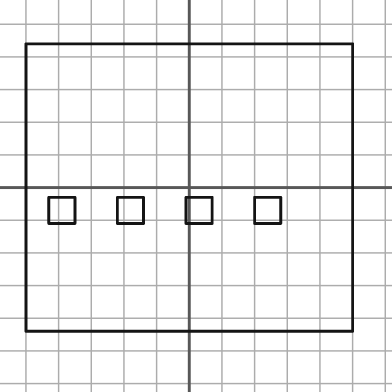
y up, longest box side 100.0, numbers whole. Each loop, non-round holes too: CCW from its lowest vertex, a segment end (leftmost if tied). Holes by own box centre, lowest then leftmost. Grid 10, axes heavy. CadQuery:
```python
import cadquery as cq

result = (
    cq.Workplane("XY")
    .moveTo(-50.0, -44.0)
    .lineTo(50.0, -44.0)
    .lineTo(50.0, 44.0)
    .lineTo(-50.0, 44.0)
    .close()
    .moveTo(-43.0, -11.0)
    .lineTo(-35.0, -11.0)
    .lineTo(-35.0, -3.0)
    .lineTo(-43.0, -3.0)
    .close()
    .moveTo(-22.0, -11.0)
    .lineTo(-14.0, -11.0)
    .lineTo(-14.0, -3.0)
    .lineTo(-22.0, -3.0)
    .close()
    .moveTo(-1.0, -11.0)
    .lineTo(7.0, -11.0)
    .lineTo(7.0, -3.0)
    .lineTo(-1.0, -3.0)
    .close()
    .moveTo(20.0, -11.0)
    .lineTo(28.0, -11.0)
    .lineTo(28.0, -3.0)
    .lineTo(20.0, -3.0)
    .close()
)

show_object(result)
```